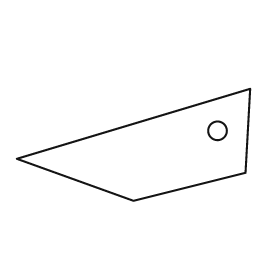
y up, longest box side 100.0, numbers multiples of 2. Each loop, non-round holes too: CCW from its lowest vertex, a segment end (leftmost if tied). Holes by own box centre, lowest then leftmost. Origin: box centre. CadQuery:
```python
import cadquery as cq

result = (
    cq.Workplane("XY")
    .moveTo(0.0, -24.0)
    .lineTo(48.0, -12.0)
    .lineTo(50.0, 24.0)
    .lineTo(-50.0, -6.0)
    .close()
    .moveTo(36.0, 6.0)
    .circle(4.0)
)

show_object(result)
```